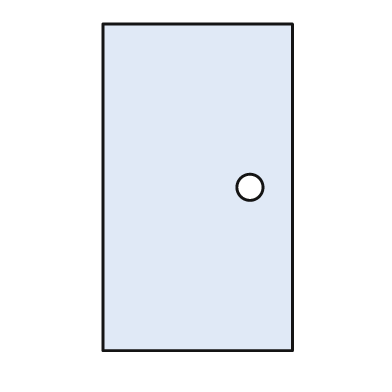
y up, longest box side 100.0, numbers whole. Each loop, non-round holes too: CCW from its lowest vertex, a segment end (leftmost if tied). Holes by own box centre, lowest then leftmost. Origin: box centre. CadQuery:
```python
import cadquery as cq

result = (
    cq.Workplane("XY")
    .moveTo(-29.0, -50.0)
    .lineTo(29.0, -50.0)
    .lineTo(29.0, 50.0)
    .lineTo(-29.0, 50.0)
    .close()
    .moveTo(16.0, 0.0)
    .circle(4.0)
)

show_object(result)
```